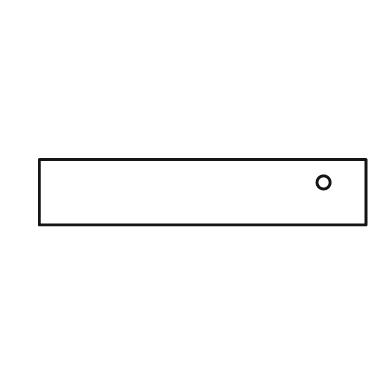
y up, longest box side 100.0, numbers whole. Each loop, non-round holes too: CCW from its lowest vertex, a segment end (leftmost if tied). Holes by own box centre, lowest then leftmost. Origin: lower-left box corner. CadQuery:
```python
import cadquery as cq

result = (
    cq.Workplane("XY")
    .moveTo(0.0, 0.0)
    .lineTo(100.0, 0.0)
    .lineTo(100.0, 20.0)
    .lineTo(0.0, 20.0)
    .close()
    .moveTo(87.0, 13.0)
    .circle(2.0)
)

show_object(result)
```